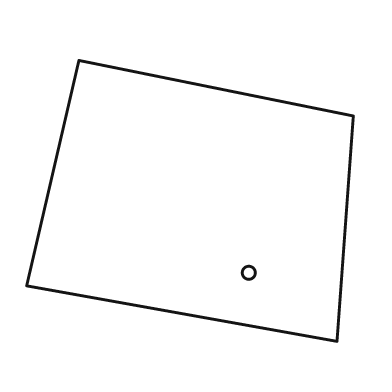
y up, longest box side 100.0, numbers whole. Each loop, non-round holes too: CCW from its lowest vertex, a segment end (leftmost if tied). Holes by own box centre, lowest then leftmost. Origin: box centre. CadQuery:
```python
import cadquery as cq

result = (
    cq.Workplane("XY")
    .moveTo(45.0, -43.0)
    .lineTo(50.0, 26.0)
    .lineTo(-34.0, 43.0)
    .lineTo(-50.0, -26.0)
    .close()
    .moveTo(18.0, -22.0)
    .circle(2.0)
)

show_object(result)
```